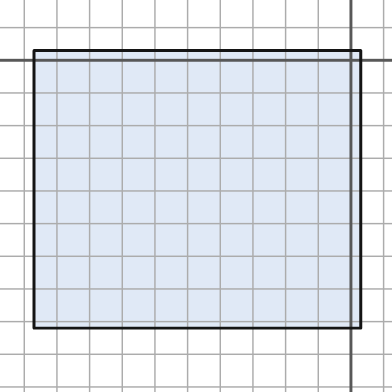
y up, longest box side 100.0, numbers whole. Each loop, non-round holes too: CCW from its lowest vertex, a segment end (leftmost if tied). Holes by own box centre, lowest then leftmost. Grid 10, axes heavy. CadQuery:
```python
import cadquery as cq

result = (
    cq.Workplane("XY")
    .moveTo(-97.0, -82.0)
    .lineTo(3.0, -82.0)
    .lineTo(3.0, 3.0)
    .lineTo(-97.0, 3.0)
    .close()
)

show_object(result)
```